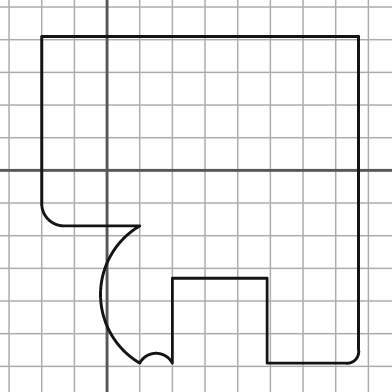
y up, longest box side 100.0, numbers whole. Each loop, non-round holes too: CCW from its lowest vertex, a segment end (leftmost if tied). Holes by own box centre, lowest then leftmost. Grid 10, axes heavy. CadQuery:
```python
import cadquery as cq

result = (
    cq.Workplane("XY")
    .moveTo(10.0, -59.0)
    .threePointArc((15.0, -56.0), (20.0, -59.0))
    .lineTo(20.0, -33.0)
    .lineTo(49.0, -33.0)
    .lineTo(49.0, -59.0)
    .lineTo(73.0, -59.0)
    .threePointArc((76.0, -58.0), (77.0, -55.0))
    .lineTo(77.0, 41.0)
    .lineTo(-20.0, 41.0)
    .lineTo(-20.0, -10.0)
    .threePointArc((-18.0, -15.0), (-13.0, -17.0))
    .lineTo(10.0, -17.0)
    .threePointArc((-2.0, -38.0), (10.0, -59.0))
    .close()
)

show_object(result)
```